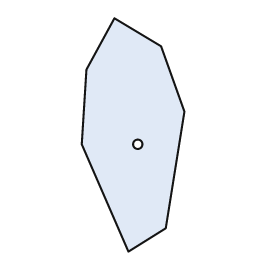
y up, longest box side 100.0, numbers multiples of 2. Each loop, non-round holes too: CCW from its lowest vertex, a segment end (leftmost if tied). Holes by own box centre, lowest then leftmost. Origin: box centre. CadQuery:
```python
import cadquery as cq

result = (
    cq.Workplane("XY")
    .moveTo(-2.0, -50.0)
    .lineTo(14.0, -40.0)
    .lineTo(22.0, 10.0)
    .lineTo(12.0, 38.0)
    .lineTo(-8.0, 50.0)
    .lineTo(-20.0, 28.0)
    .lineTo(-22.0, -4.0)
    .close()
    .moveTo(2.0, -4.0)
    .circle(2.0)
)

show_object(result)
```